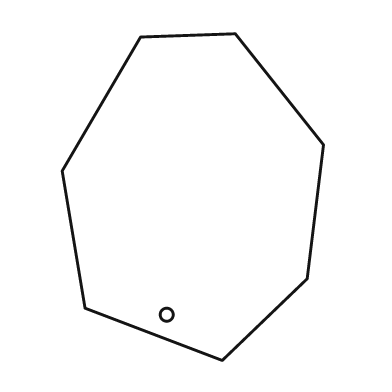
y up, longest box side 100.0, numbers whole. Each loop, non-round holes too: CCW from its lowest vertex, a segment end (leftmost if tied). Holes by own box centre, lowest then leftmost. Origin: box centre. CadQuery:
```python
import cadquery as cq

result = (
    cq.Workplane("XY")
    .moveTo(9.0, -50.0)
    .lineTo(35.0, -25.0)
    .lineTo(40.0, 16.0)
    .lineTo(13.0, 50.0)
    .lineTo(-16.0, 49.0)
    .lineTo(-40.0, 8.0)
    .lineTo(-33.0, -34.0)
    .close()
    .moveTo(-8.0, -36.0)
    .circle(2.0)
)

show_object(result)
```